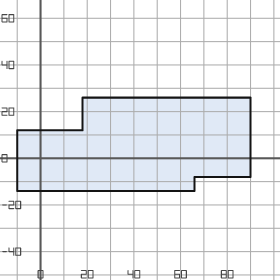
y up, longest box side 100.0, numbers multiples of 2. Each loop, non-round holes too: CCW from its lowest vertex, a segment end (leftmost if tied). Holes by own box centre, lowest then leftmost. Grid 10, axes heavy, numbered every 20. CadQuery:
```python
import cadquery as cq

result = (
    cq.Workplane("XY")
    .moveTo(-10.0, -14.0)
    .lineTo(66.0, -14.0)
    .lineTo(66.0, -8.0)
    .lineTo(90.0, -8.0)
    .lineTo(90.0, 26.0)
    .lineTo(18.0, 26.0)
    .lineTo(18.0, 12.0)
    .lineTo(-10.0, 12.0)
    .close()
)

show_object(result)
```